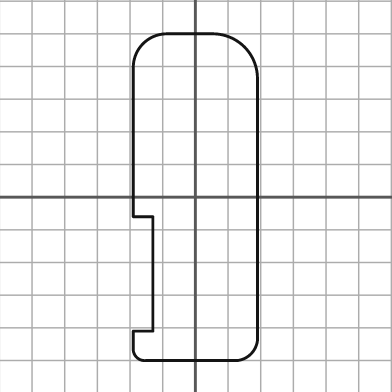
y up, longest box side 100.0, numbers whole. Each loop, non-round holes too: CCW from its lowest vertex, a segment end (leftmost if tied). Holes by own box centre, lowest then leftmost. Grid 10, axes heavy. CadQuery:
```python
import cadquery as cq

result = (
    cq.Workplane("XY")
    .moveTo(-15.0, -50.0)
    .lineTo(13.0, -50.0)
    .threePointArc((17.0, -48.0), (19.0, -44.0))
    .lineTo(19.0, 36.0)
    .threePointArc((15.0, 46.0), (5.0, 50.0))
    .lineTo(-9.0, 50.0)
    .threePointArc((-16.0, 47.0), (-19.0, 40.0))
    .lineTo(-19.0, -6.0)
    .lineTo(-13.0, -6.0)
    .lineTo(-13.0, -41.0)
    .lineTo(-19.0, -41.0)
    .lineTo(-19.0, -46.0)
    .threePointArc((-18.0, -49.0), (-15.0, -50.0))
    .close()
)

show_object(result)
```